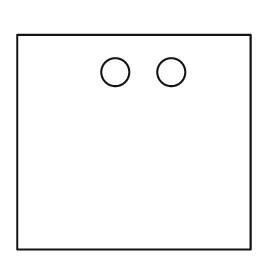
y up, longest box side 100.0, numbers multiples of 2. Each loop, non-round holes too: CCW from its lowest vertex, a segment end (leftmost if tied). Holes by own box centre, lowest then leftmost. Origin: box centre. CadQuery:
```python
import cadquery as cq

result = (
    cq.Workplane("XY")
    .moveTo(-50.0, -46.0)
    .lineTo(50.0, -46.0)
    .lineTo(50.0, 46.0)
    .lineTo(-50.0, 46.0)
    .close()
    .moveTo(-8.0, 30.0)
    .circle(6.0)
    .moveTo(16.0, 30.0)
    .circle(6.0)
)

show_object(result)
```